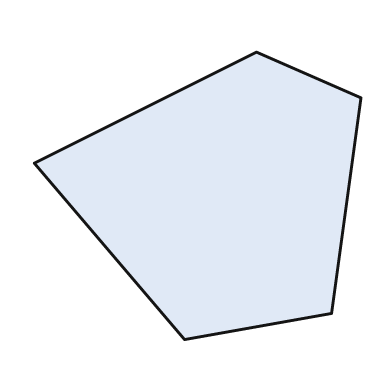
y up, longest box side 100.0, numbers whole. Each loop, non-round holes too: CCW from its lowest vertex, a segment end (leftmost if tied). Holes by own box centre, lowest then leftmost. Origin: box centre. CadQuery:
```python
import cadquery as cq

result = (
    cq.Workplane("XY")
    .moveTo(-4.0, -44.0)
    .lineTo(41.0, -36.0)
    .lineTo(50.0, 30.0)
    .lineTo(18.0, 44.0)
    .lineTo(-50.0, 10.0)
    .close()
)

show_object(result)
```